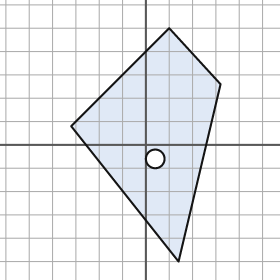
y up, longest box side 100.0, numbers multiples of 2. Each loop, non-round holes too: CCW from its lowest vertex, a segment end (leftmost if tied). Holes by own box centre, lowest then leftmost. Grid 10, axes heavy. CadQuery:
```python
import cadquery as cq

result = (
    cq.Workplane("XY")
    .moveTo(14.0, -50.0)
    .lineTo(32.0, 26.0)
    .lineTo(10.0, 50.0)
    .lineTo(-32.0, 8.0)
    .close()
    .moveTo(4.0, -6.0)
    .circle(4.0)
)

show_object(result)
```